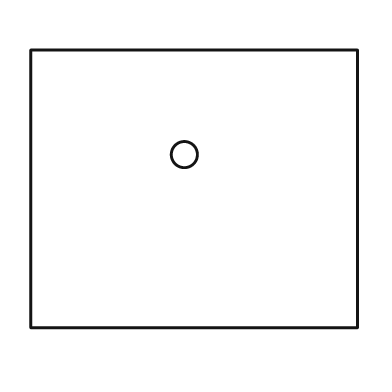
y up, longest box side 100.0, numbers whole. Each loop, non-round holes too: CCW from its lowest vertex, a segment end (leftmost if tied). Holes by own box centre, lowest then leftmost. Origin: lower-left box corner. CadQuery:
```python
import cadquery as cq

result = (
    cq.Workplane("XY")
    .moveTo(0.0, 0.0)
    .lineTo(100.0, 0.0)
    .lineTo(100.0, 85.0)
    .lineTo(0.0, 85.0)
    .close()
    .moveTo(47.0, 53.0)
    .circle(4.0)
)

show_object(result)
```